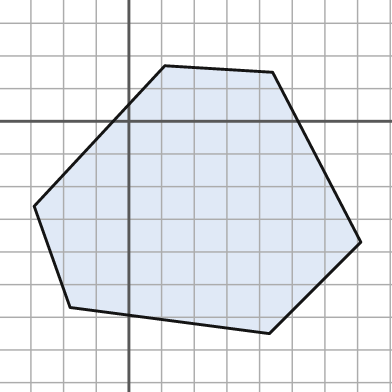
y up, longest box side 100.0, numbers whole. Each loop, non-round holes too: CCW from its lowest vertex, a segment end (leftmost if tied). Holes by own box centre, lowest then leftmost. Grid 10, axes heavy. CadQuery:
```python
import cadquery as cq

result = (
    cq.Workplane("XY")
    .moveTo(43.0, -65.0)
    .lineTo(71.0, -37.0)
    .lineTo(44.0, 15.0)
    .lineTo(11.0, 17.0)
    .lineTo(-29.0, -26.0)
    .lineTo(-18.0, -57.0)
    .close()
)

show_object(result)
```